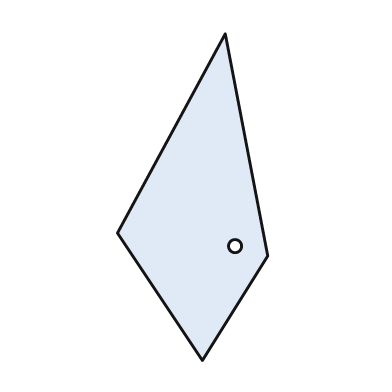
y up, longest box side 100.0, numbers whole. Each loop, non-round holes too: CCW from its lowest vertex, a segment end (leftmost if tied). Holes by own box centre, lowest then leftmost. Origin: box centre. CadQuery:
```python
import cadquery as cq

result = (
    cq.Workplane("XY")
    .moveTo(3.0, -50.0)
    .lineTo(23.0, -18.0)
    .lineTo(10.0, 50.0)
    .lineTo(-23.0, -11.0)
    .close()
    .moveTo(13.0, -15.0)
    .circle(2.0)
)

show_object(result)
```